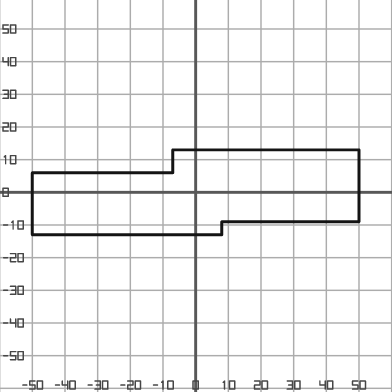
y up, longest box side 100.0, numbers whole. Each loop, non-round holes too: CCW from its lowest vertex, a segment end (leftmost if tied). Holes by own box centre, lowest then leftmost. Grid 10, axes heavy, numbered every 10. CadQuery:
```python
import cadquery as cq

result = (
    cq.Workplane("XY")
    .moveTo(-50.0, -13.0)
    .lineTo(8.0, -13.0)
    .lineTo(8.0, -9.0)
    .lineTo(50.0, -9.0)
    .lineTo(50.0, 13.0)
    .lineTo(-7.0, 13.0)
    .lineTo(-7.0, 6.0)
    .lineTo(-50.0, 6.0)
    .close()
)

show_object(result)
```